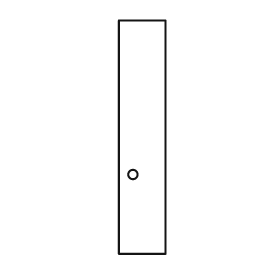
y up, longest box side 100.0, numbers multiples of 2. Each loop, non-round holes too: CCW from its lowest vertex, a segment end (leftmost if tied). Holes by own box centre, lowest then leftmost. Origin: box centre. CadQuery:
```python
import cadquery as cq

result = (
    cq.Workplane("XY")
    .moveTo(-10.0, -50.0)
    .lineTo(10.0, -50.0)
    .lineTo(10.0, 50.0)
    .lineTo(-10.0, 50.0)
    .close()
    .moveTo(-4.0, -16.0)
    .circle(2.0)
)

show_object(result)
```